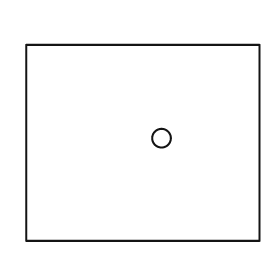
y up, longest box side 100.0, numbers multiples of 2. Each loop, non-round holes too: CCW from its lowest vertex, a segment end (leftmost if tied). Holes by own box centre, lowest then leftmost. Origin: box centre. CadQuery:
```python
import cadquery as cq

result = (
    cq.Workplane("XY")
    .moveTo(-50.0, -42.0)
    .lineTo(50.0, -42.0)
    .lineTo(50.0, 42.0)
    .lineTo(-50.0, 42.0)
    .close()
    .moveTo(8.0, 2.0)
    .circle(4.0)
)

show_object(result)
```